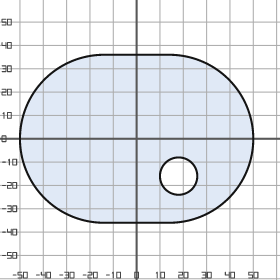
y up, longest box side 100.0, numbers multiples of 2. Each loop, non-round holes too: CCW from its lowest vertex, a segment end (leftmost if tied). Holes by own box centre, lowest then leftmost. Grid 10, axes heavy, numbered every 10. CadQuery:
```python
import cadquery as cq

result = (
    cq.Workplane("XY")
    .moveTo(-14.0, -36.0)
    .lineTo(14.0, -36.0)
    .threePointArc((50.0, 0.0), (14.0, 36.0))
    .lineTo(-14.0, 36.0)
    .threePointArc((-50.0, 0.0), (-14.0, -36.0))
    .close()
    .moveTo(18.0, -16.0)
    .circle(8.0)
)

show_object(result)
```